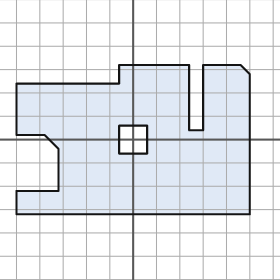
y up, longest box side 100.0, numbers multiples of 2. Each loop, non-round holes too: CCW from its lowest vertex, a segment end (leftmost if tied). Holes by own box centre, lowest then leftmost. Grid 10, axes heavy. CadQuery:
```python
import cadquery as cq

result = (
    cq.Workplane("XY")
    .moveTo(-50.0, -32.0)
    .lineTo(50.0, -32.0)
    .lineTo(50.0, 28.0)
    .lineTo(46.0, 32.0)
    .lineTo(30.0, 32.0)
    .lineTo(30.0, 4.0)
    .lineTo(24.0, 4.0)
    .lineTo(24.0, 32.0)
    .lineTo(-6.0, 32.0)
    .lineTo(-6.0, 24.0)
    .lineTo(-50.0, 24.0)
    .lineTo(-50.0, 2.0)
    .lineTo(-38.0, 2.0)
    .lineTo(-32.0, -4.0)
    .lineTo(-32.0, -22.0)
    .lineTo(-50.0, -22.0)
    .close()
    .moveTo(-6.0, -6.0)
    .lineTo(6.0, -6.0)
    .lineTo(6.0, 6.0)
    .lineTo(-6.0, 6.0)
    .close()
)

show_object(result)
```